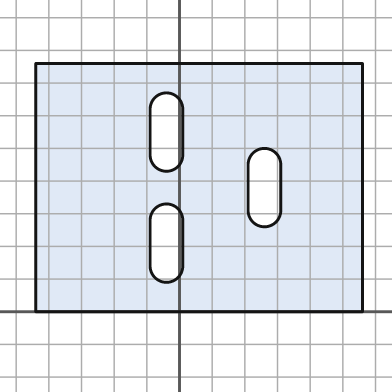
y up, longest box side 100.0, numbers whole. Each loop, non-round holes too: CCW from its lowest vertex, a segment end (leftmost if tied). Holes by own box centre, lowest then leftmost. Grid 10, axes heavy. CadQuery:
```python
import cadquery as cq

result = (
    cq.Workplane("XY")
    .moveTo(-44.0, 0.0)
    .lineTo(56.0, 0.0)
    .lineTo(56.0, 76.0)
    .lineTo(-44.0, 76.0)
    .close()
    .moveTo(-9.0, 14.0)
    .threePointArc((-4.0, 9.0), (1.0, 14.0))
    .lineTo(1.0, 28.0)
    .threePointArc((-4.0, 33.0), (-9.0, 28.0))
    .close()
    .moveTo(21.0, 31.0)
    .threePointArc((26.0, 26.0), (31.0, 31.0))
    .lineTo(31.0, 45.0)
    .threePointArc((26.0, 50.0), (21.0, 45.0))
    .close()
    .moveTo(-9.0, 48.0)
    .threePointArc((-4.0, 43.0), (1.0, 48.0))
    .lineTo(1.0, 62.0)
    .threePointArc((-4.0, 67.0), (-9.0, 62.0))
    .close()
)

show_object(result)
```